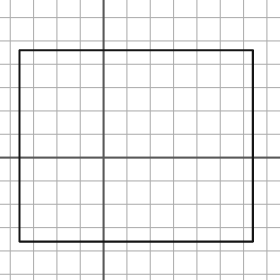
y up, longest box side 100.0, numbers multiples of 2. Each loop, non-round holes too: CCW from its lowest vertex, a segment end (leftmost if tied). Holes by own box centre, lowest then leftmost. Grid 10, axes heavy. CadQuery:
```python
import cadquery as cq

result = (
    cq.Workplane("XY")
    .moveTo(-36.0, -36.0)
    .lineTo(64.0, -36.0)
    .lineTo(64.0, 46.0)
    .lineTo(-36.0, 46.0)
    .close()
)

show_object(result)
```